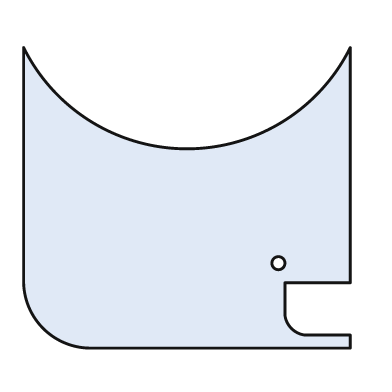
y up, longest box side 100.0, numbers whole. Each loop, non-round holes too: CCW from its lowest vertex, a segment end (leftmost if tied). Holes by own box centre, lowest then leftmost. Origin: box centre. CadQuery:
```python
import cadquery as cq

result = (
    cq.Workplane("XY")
    .moveTo(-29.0, -46.0)
    .lineTo(50.0, -46.0)
    .lineTo(50.0, -42.0)
    .lineTo(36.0, -42.0)
    .threePointArc((32.0, -40.0), (30.0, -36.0))
    .lineTo(30.0, -26.0)
    .lineTo(50.0, -26.0)
    .lineTo(50.0, 46.0)
    .threePointArc((0.0, 15.0), (-50.0, 46.0))
    .lineTo(-50.0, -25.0)
    .threePointArc((-44.0, -40.0), (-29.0, -46.0))
    .close()
    .moveTo(28.0, -20.0)
    .circle(2.0)
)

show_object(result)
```